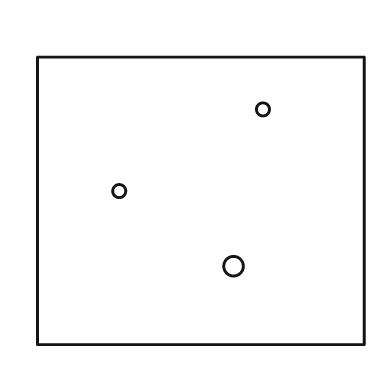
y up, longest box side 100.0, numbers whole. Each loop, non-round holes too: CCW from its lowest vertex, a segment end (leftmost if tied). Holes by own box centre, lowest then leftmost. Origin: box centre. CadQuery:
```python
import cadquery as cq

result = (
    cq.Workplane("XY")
    .moveTo(-50.0, -44.0)
    .lineTo(50.0, -44.0)
    .lineTo(50.0, 44.0)
    .lineTo(-50.0, 44.0)
    .close()
    .moveTo(10.0, -20.0)
    .circle(3.0)
    .moveTo(-25.0, 3.0)
    .circle(2.0)
    .moveTo(19.0, 28.0)
    .circle(2.0)
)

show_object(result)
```